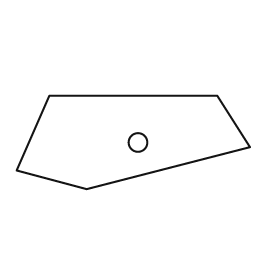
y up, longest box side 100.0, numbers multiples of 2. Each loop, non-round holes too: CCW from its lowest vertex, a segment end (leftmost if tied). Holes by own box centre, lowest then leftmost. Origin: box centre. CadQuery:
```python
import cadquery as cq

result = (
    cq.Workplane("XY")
    .moveTo(-20.0, -20.0)
    .lineTo(50.0, -2.0)
    .lineTo(36.0, 20.0)
    .lineTo(-36.0, 20.0)
    .lineTo(-50.0, -12.0)
    .close()
    .moveTo(2.0, 0.0)
    .circle(4.0)
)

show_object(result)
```